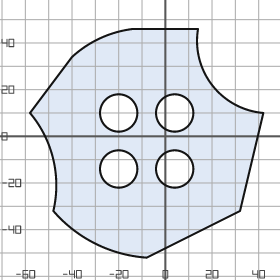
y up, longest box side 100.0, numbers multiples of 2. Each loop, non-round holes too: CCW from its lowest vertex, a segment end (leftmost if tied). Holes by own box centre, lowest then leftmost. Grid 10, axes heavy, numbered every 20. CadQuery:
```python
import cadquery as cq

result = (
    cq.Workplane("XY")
    .moveTo(-8.0, -52.0)
    .lineTo(32.0, -32.0)
    .lineTo(42.0, 10.0)
    .threePointArc((20.0, 22.0), (14.0, 46.0))
    .lineTo(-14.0, 46.0)
    .threePointArc((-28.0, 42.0), (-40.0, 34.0))
    .lineTo(-58.0, 10.0)
    .threePointArc((-48.0, -10.0), (-48.0, -32.0))
    .threePointArc((-30.0, -46.0), (-8.0, -52.0))
    .close()
    .moveTo(-20.0, -14.0)
    .circle(8.0)
    .moveTo(4.0, -14.0)
    .circle(8.0)
    .moveTo(-20.0, 10.0)
    .circle(8.0)
    .moveTo(4.0, 10.0)
    .circle(8.0)
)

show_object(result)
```